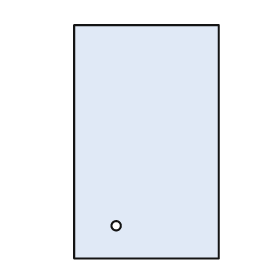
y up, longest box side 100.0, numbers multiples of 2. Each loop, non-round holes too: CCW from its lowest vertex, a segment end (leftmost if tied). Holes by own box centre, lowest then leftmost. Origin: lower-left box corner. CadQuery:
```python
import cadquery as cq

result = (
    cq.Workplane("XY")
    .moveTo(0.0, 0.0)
    .lineTo(62.0, 0.0)
    .lineTo(62.0, 100.0)
    .lineTo(0.0, 100.0)
    .close()
    .moveTo(18.0, 14.0)
    .circle(2.0)
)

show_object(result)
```